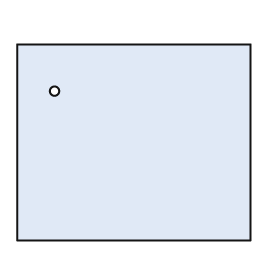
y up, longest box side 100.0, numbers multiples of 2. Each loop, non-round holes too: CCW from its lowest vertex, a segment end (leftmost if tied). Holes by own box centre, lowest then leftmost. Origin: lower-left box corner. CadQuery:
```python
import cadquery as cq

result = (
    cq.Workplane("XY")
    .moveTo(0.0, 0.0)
    .lineTo(100.0, 0.0)
    .lineTo(100.0, 84.0)
    .lineTo(0.0, 84.0)
    .close()
    .moveTo(16.0, 64.0)
    .circle(2.0)
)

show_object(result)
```